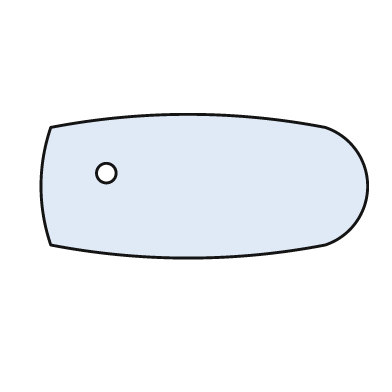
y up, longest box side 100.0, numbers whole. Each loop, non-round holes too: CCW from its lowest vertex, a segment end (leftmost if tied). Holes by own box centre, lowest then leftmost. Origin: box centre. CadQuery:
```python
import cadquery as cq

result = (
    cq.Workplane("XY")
    .moveTo(-47.0, -18.0)
    .threePointArc((-5.0, -22.0), (37.0, -18.0))
    .threePointArc((50.0, 0.0), (37.0, 18.0))
    .threePointArc((-5.0, 22.0), (-47.0, 18.0))
    .threePointArc((-50.0, 0.0), (-47.0, -18.0))
    .close()
    .moveTo(-30.0, 4.0)
    .circle(3.0)
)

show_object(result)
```